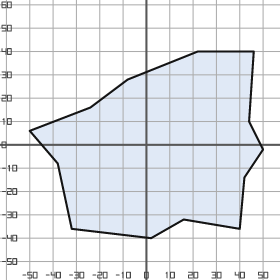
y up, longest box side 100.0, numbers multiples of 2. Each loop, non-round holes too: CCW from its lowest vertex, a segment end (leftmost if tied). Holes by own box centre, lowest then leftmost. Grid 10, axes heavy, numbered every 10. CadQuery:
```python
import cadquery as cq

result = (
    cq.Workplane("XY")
    .moveTo(2.0, -40.0)
    .lineTo(16.0, -32.0)
    .lineTo(40.0, -36.0)
    .lineTo(42.0, -14.0)
    .lineTo(50.0, -2.0)
    .lineTo(44.0, 10.0)
    .lineTo(46.0, 40.0)
    .lineTo(22.0, 40.0)
    .lineTo(-8.0, 28.0)
    .lineTo(-24.0, 16.0)
    .lineTo(-50.0, 6.0)
    .lineTo(-38.0, -8.0)
    .lineTo(-32.0, -36.0)
    .close()
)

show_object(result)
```